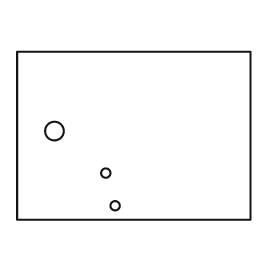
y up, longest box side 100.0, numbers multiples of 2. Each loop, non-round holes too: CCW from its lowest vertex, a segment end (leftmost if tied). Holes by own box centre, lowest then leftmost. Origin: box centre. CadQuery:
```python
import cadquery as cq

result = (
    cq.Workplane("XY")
    .moveTo(-50.0, -36.0)
    .lineTo(50.0, -36.0)
    .lineTo(50.0, 36.0)
    .lineTo(-50.0, 36.0)
    .close()
    .moveTo(-8.0, -30.0)
    .circle(2.0)
    .moveTo(-12.0, -16.0)
    .circle(2.0)
    .moveTo(-34.0, 2.0)
    .circle(4.0)
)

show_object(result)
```